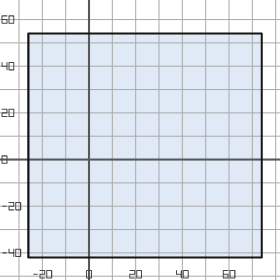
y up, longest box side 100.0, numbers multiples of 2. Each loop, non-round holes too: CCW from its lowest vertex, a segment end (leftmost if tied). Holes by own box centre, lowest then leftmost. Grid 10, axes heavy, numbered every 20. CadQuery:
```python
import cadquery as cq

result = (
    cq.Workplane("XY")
    .moveTo(-26.0, -42.0)
    .lineTo(74.0, -42.0)
    .lineTo(74.0, 54.0)
    .lineTo(-26.0, 54.0)
    .close()
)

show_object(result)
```